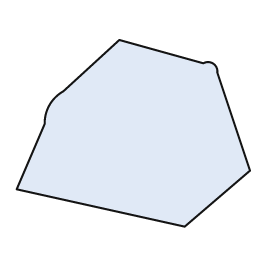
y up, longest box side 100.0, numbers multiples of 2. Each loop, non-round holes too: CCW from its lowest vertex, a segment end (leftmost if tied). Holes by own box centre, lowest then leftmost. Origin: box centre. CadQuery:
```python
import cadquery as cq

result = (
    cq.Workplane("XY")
    .moveTo(22.0, -40.0)
    .lineTo(50.0, -16.0)
    .lineTo(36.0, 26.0)
    .threePointArc((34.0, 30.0), (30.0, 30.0))
    .lineTo(-6.0, 40.0)
    .lineTo(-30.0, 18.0)
    .threePointArc((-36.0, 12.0), (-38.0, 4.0))
    .lineTo(-50.0, -24.0)
    .close()
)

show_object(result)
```